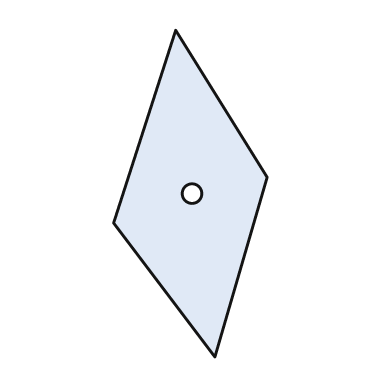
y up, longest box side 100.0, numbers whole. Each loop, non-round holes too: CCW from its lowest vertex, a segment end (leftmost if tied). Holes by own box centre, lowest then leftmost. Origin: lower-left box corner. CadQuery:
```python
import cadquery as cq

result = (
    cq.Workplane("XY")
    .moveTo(31.0, 0.0)
    .lineTo(47.0, 55.0)
    .lineTo(19.0, 100.0)
    .lineTo(0.0, 41.0)
    .close()
    .moveTo(24.0, 50.0)
    .circle(3.0)
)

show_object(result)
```